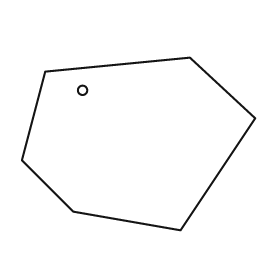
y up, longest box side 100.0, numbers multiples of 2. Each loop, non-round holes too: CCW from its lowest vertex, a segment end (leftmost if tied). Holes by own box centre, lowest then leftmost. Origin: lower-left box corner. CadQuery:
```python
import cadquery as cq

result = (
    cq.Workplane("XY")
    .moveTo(68.0, 0.0)
    .lineTo(100.0, 48.0)
    .lineTo(72.0, 74.0)
    .lineTo(10.0, 68.0)
    .lineTo(0.0, 30.0)
    .lineTo(22.0, 8.0)
    .close()
    .moveTo(26.0, 60.0)
    .circle(2.0)
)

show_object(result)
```